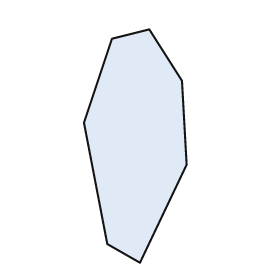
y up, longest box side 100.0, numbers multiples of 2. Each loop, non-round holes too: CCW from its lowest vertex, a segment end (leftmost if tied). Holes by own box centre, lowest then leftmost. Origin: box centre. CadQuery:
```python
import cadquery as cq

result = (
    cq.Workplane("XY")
    .moveTo(2.0, -50.0)
    .lineTo(22.0, -8.0)
    .lineTo(20.0, 28.0)
    .lineTo(6.0, 50.0)
    .lineTo(-10.0, 46.0)
    .lineTo(-22.0, 10.0)
    .lineTo(-12.0, -42.0)
    .close()
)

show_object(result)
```